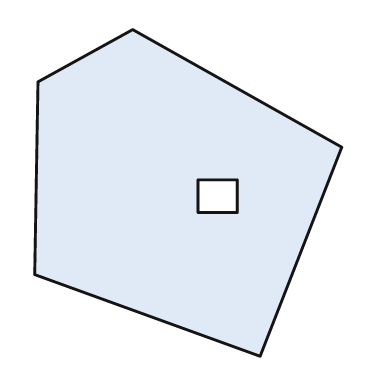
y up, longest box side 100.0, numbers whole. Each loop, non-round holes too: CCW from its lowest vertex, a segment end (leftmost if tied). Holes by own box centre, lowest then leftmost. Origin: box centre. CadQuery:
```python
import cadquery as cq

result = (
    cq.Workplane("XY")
    .moveTo(22.0, -50.0)
    .lineTo(47.0, 14.0)
    .lineTo(-17.0, 50.0)
    .lineTo(-46.0, 34.0)
    .lineTo(-47.0, -25.0)
    .close()
    .moveTo(3.0, -6.0)
    .lineTo(15.0, -6.0)
    .lineTo(15.0, 4.0)
    .lineTo(3.0, 4.0)
    .close()
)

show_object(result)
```